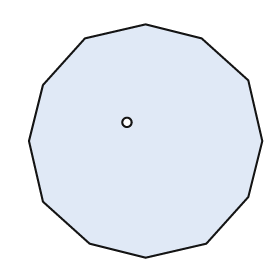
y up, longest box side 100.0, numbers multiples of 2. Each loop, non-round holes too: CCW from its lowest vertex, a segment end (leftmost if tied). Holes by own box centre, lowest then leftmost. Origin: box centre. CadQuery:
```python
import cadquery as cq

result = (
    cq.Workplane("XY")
    .moveTo(0.0, -50.0)
    .lineTo(26.0, -44.0)
    .lineTo(44.0, -24.0)
    .lineTo(50.0, 0.0)
    .lineTo(44.0, 26.0)
    .lineTo(24.0, 44.0)
    .lineTo(0.0, 50.0)
    .lineTo(-26.0, 44.0)
    .lineTo(-44.0, 24.0)
    .lineTo(-50.0, 0.0)
    .lineTo(-44.0, -26.0)
    .lineTo(-24.0, -44.0)
    .close()
    .moveTo(-8.0, 8.0)
    .circle(2.0)
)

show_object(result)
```